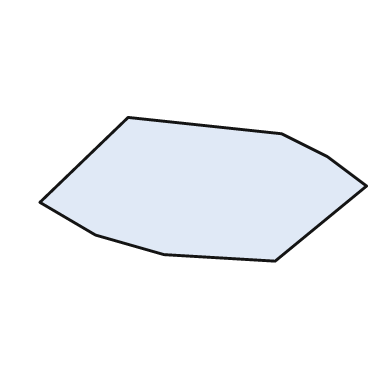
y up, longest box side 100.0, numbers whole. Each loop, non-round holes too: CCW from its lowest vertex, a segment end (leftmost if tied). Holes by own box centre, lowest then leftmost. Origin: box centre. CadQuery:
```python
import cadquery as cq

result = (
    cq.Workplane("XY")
    .moveTo(22.0, -22.0)
    .lineTo(50.0, 1.0)
    .lineTo(38.0, 10.0)
    .lineTo(24.0, 17.0)
    .lineTo(-23.0, 22.0)
    .lineTo(-50.0, -4.0)
    .lineTo(-33.0, -14.0)
    .lineTo(-12.0, -20.0)
    .close()
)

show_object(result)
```